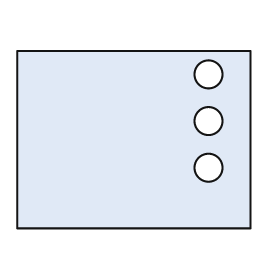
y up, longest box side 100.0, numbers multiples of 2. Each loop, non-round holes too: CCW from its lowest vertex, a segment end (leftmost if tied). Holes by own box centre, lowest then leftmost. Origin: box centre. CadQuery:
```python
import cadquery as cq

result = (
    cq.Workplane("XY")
    .moveTo(-50.0, -38.0)
    .lineTo(50.0, -38.0)
    .lineTo(50.0, 38.0)
    .lineTo(-50.0, 38.0)
    .close()
    .moveTo(32.0, -12.0)
    .circle(6.0)
    .moveTo(32.0, 8.0)
    .circle(6.0)
    .moveTo(32.0, 28.0)
    .circle(6.0)
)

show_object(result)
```